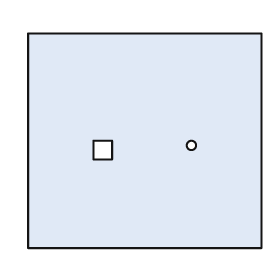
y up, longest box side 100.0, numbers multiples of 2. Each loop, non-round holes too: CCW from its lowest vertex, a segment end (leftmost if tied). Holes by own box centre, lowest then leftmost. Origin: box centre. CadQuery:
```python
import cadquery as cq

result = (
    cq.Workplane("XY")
    .moveTo(-50.0, -46.0)
    .lineTo(50.0, -46.0)
    .lineTo(50.0, 46.0)
    .lineTo(-50.0, 46.0)
    .close()
    .moveTo(-22.0, -8.0)
    .lineTo(-14.0, -8.0)
    .lineTo(-14.0, 0.0)
    .lineTo(-22.0, 0.0)
    .close()
    .moveTo(20.0, -2.0)
    .circle(2.0)
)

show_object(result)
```